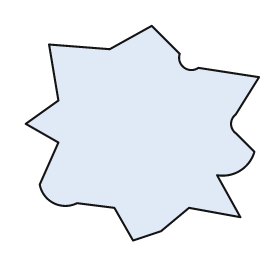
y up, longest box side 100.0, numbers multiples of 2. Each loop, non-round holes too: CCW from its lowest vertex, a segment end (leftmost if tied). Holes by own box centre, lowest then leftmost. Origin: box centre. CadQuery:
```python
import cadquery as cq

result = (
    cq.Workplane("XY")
    .moveTo(-4.0, -46.0)
    .lineTo(8.0, -42.0)
    .lineTo(20.0, -32.0)
    .lineTo(42.0, -36.0)
    .lineTo(32.0, -18.0)
    .threePointArc((42.0, -16.0), (48.0, -8.0))
    .lineTo(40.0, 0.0)
    .threePointArc((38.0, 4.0), (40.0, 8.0))
    .lineTo(50.0, 24.0)
    .lineTo(24.0, 28.0)
    .threePointArc((18.0, 28.0), (16.0, 34.0))
    .lineTo(4.0, 46.0)
    .lineTo(-14.0, 36.0)
    .lineTo(-40.0, 38.0)
    .lineTo(-36.0, 14.0)
    .lineTo(-50.0, 4.0)
    .lineTo(-36.0, -4.0)
    .lineTo(-44.0, -22.0)
    .threePointArc((-38.0, -30.0), (-28.0, -30.0))
    .lineTo(-12.0, -32.0)
    .close()
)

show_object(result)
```